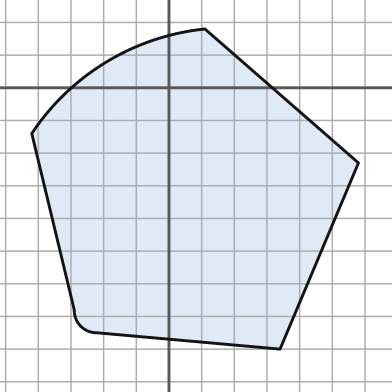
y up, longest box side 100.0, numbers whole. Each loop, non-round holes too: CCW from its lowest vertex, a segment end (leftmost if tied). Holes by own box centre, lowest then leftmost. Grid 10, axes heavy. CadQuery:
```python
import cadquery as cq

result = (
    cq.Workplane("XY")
    .moveTo(34.0, -80.0)
    .lineTo(58.0, -23.0)
    .lineTo(11.0, 18.0)
    .threePointArc((-19.0, 8.0), (-42.0, -14.0))
    .lineTo(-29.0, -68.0)
    .threePointArc((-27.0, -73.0), (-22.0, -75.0))
    .close()
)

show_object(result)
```